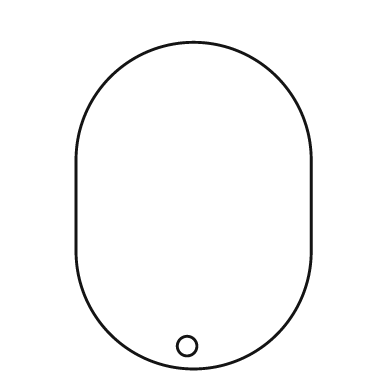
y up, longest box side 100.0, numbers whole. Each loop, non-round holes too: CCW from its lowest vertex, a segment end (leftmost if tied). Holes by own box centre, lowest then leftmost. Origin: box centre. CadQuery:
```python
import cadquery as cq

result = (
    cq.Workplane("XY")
    .moveTo(-36.0, -14.0)
    .threePointArc((0.0, -50.0), (36.0, -14.0))
    .lineTo(36.0, 14.0)
    .threePointArc((0.0, 50.0), (-36.0, 14.0))
    .close()
    .moveTo(-2.0, -43.0)
    .circle(3.0)
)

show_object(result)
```